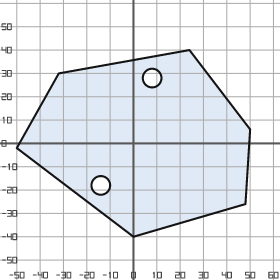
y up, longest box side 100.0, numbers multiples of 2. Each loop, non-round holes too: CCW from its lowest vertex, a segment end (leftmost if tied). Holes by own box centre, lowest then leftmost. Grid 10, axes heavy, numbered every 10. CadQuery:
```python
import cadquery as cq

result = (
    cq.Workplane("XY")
    .moveTo(0.0, -40.0)
    .lineTo(48.0, -26.0)
    .lineTo(50.0, 6.0)
    .lineTo(24.0, 40.0)
    .lineTo(-32.0, 30.0)
    .lineTo(-50.0, -2.0)
    .close()
    .moveTo(-14.0, -18.0)
    .circle(4.0)
    .moveTo(8.0, 28.0)
    .circle(4.0)
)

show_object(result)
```